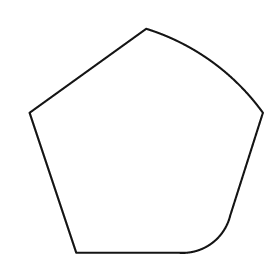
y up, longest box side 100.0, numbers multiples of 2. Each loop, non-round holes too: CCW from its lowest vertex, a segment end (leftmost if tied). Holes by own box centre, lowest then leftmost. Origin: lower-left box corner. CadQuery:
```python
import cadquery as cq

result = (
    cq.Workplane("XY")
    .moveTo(20.0, 0.0)
    .lineTo(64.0, 0.0)
    .threePointArc((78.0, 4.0), (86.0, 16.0))
    .lineTo(100.0, 60.0)
    .threePointArc((78.0, 82.0), (50.0, 96.0))
    .lineTo(0.0, 60.0)
    .close()
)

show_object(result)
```